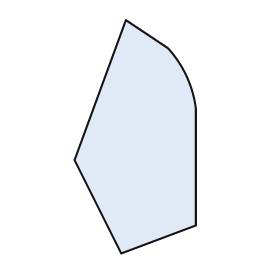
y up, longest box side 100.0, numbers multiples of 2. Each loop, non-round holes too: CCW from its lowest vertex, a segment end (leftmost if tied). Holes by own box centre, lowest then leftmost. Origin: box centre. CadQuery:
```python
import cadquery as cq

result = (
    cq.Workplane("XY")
    .moveTo(-6.0, -50.0)
    .lineTo(26.0, -38.0)
    .lineTo(26.0, 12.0)
    .threePointArc((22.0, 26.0), (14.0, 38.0))
    .lineTo(-4.0, 50.0)
    .lineTo(-26.0, -10.0)
    .close()
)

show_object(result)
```